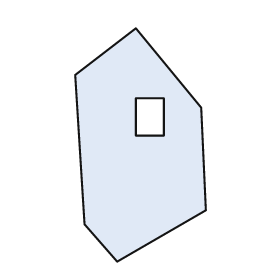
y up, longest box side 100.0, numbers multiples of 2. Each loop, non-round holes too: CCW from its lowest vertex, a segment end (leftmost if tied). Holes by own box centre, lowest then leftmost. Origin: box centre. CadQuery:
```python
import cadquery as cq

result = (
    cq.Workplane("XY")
    .moveTo(-10.0, -50.0)
    .lineTo(28.0, -28.0)
    .lineTo(26.0, 16.0)
    .lineTo(-2.0, 50.0)
    .lineTo(-28.0, 30.0)
    .lineTo(-24.0, -34.0)
    .close()
    .moveTo(-2.0, 4.0)
    .lineTo(10.0, 4.0)
    .lineTo(10.0, 20.0)
    .lineTo(-2.0, 20.0)
    .close()
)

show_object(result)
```